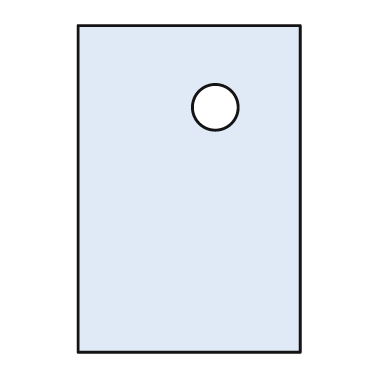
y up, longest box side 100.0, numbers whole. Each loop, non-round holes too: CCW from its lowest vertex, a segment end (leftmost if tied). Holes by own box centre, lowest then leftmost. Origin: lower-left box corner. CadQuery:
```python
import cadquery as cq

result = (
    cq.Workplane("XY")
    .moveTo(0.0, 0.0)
    .lineTo(68.0, 0.0)
    .lineTo(68.0, 100.0)
    .lineTo(0.0, 100.0)
    .close()
    .moveTo(42.0, 75.0)
    .circle(7.0)
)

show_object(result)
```